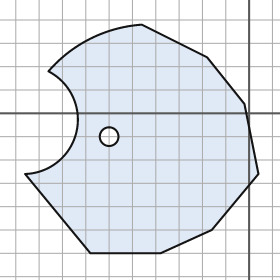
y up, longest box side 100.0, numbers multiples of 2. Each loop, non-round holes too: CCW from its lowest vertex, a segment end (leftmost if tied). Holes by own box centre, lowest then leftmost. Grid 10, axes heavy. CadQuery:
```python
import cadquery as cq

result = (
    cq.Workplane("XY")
    .moveTo(-68.0, -60.0)
    .lineTo(-38.0, -60.0)
    .lineTo(-16.0, -50.0)
    .lineTo(4.0, -26.0)
    .lineTo(-2.0, 4.0)
    .lineTo(-18.0, 24.0)
    .lineTo(-46.0, 38.0)
    .threePointArc((-68.0, 32.0), (-86.0, 18.0))
    .threePointArc((-74.0, -8.0), (-96.0, -26.0))
    .close()
    .moveTo(-60.0, -10.0)
    .circle(4.0)
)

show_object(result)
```